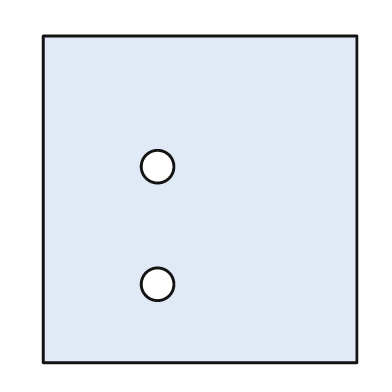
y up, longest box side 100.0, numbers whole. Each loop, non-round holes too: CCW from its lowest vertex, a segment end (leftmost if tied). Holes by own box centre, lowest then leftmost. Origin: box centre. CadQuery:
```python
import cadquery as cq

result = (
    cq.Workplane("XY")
    .moveTo(-48.0, -50.0)
    .lineTo(48.0, -50.0)
    .lineTo(48.0, 50.0)
    .lineTo(-48.0, 50.0)
    .close()
    .moveTo(-13.0, -26.0)
    .circle(5.0)
    .moveTo(-13.0, 10.0)
    .circle(5.0)
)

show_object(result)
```